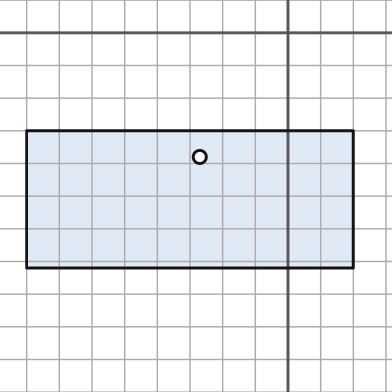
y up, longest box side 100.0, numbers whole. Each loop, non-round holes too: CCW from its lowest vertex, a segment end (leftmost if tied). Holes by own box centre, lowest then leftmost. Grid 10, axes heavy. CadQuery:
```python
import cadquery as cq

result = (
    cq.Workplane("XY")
    .moveTo(-80.0, -72.0)
    .lineTo(20.0, -72.0)
    .lineTo(20.0, -30.0)
    .lineTo(-80.0, -30.0)
    .close()
    .moveTo(-27.0, -38.0)
    .circle(2.0)
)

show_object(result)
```